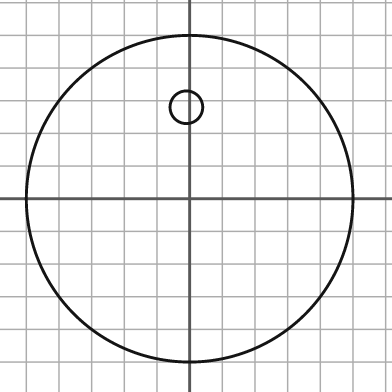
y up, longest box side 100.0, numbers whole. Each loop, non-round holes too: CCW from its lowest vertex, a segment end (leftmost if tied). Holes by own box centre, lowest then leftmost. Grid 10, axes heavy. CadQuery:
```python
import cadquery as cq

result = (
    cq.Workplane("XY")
    .moveTo(0.0, 0.0)
    .circle(50.0)
    .moveTo(-1.0, 28.0)
    .circle(5.0)
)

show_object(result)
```